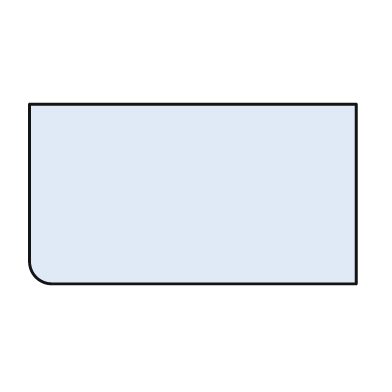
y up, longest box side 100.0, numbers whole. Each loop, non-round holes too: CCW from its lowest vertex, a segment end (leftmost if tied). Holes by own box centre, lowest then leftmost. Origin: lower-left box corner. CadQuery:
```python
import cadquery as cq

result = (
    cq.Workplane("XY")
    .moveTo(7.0, 0.0)
    .lineTo(100.0, 0.0)
    .lineTo(100.0, 55.0)
    .lineTo(0.0, 55.0)
    .lineTo(0.0, 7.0)
    .threePointArc((2.0, 2.0), (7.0, 0.0))
    .close()
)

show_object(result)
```